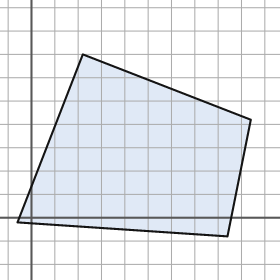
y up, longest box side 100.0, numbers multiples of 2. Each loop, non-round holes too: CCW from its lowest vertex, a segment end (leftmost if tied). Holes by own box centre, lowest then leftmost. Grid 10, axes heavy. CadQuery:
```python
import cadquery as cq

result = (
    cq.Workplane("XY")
    .moveTo(84.0, -8.0)
    .lineTo(94.0, 42.0)
    .lineTo(22.0, 70.0)
    .lineTo(-6.0, -2.0)
    .close()
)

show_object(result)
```